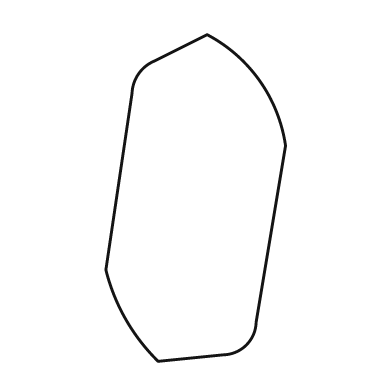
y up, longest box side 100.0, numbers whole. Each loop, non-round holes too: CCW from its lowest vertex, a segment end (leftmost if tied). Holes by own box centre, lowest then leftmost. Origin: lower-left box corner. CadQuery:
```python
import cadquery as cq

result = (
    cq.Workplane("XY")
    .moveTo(16.0, 0.0)
    .lineTo(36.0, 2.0)
    .threePointArc((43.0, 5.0), (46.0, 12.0))
    .lineTo(55.0, 66.0)
    .threePointArc((47.0, 86.0), (31.0, 100.0))
    .lineTo(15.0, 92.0)
    .threePointArc((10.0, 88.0), (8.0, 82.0))
    .lineTo(0.0, 28.0)
    .threePointArc((6.0, 13.0), (16.0, 0.0))
    .close()
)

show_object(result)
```